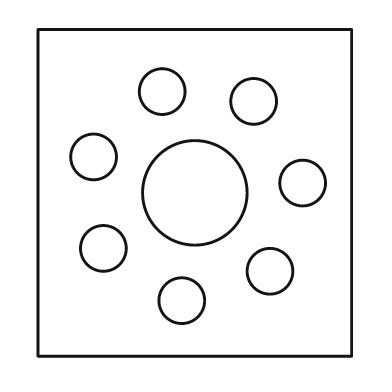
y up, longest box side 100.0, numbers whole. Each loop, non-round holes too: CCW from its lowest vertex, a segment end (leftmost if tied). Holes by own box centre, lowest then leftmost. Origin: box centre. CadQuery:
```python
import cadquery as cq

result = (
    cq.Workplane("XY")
    .moveTo(-48.0, -50.0)
    .lineTo(48.0, -50.0)
    .lineTo(48.0, 50.0)
    .lineTo(-48.0, 50.0)
    .close()
    .moveTo(-4.0, -33.0)
    .circle(7.0)
    .moveTo(23.0, -24.0)
    .circle(7.0)
    .moveTo(-28.0, -17.0)
    .circle(7.0)
    .moveTo(0.0, 0.0)
    .circle(16.0)
    .moveTo(33.0, 3.0)
    .circle(7.0)
    .moveTo(-31.0, 11.0)
    .circle(7.0)
    .moveTo(18.0, 28.0)
    .circle(7.0)
    .moveTo(-10.0, 31.0)
    .circle(7.0)
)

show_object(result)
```